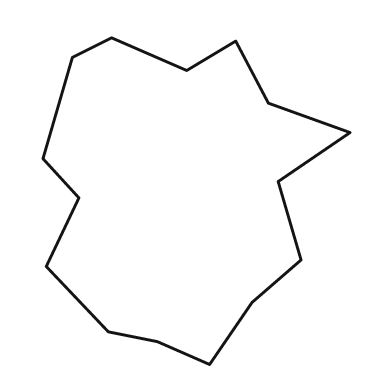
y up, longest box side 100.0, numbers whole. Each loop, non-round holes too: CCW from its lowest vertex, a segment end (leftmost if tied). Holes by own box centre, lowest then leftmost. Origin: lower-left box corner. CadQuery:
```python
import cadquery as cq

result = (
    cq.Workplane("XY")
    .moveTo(51.0, 0.0)
    .lineTo(64.0, 19.0)
    .lineTo(79.0, 32.0)
    .lineTo(72.0, 56.0)
    .lineTo(94.0, 71.0)
    .lineTo(69.0, 80.0)
    .lineTo(59.0, 99.0)
    .lineTo(44.0, 90.0)
    .lineTo(21.0, 100.0)
    .lineTo(9.0, 94.0)
    .lineTo(0.0, 63.0)
    .lineTo(11.0, 51.0)
    .lineTo(1.0, 30.0)
    .lineTo(20.0, 10.0)
    .lineTo(35.0, 7.0)
    .close()
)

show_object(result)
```